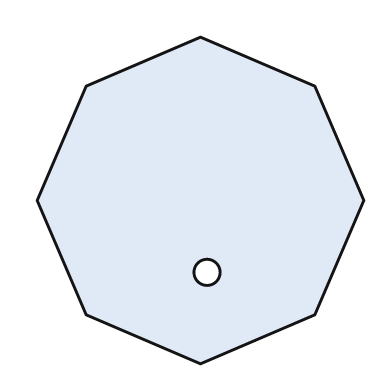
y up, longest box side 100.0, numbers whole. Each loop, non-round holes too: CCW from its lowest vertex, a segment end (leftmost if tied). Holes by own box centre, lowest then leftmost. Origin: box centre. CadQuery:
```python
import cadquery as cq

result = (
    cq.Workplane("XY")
    .moveTo(0.0, -50.0)
    .lineTo(35.0, -35.0)
    .lineTo(50.0, 0.0)
    .lineTo(35.0, 35.0)
    .lineTo(0.0, 50.0)
    .lineTo(-35.0, 35.0)
    .lineTo(-50.0, 0.0)
    .lineTo(-35.0, -35.0)
    .close()
    .moveTo(2.0, -22.0)
    .circle(4.0)
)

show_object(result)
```